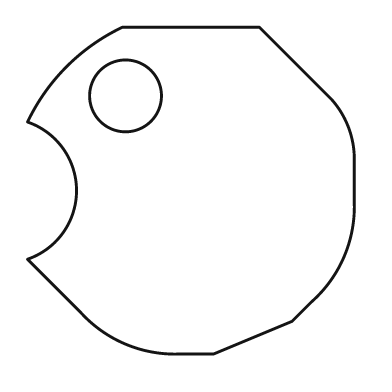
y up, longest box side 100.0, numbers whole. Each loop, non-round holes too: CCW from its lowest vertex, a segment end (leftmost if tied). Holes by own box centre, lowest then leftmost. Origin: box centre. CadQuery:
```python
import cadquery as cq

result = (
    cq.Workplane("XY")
    .moveTo(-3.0, -50.0)
    .lineTo(7.0, -50.0)
    .lineTo(31.0, -40.0)
    .lineTo(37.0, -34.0)
    .threePointArc((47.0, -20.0), (50.0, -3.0))
    .lineTo(50.0, 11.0)
    .threePointArc((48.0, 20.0), (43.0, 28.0))
    .lineTo(21.0, 50.0)
    .lineTo(-21.0, 50.0)
    .threePointArc((-38.0, 38.0), (-50.0, 21.0))
    .threePointArc((-35.0, 0.0), (-50.0, -21.0))
    .lineTo(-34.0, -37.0)
    .threePointArc((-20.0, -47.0), (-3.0, -50.0))
    .close()
    .moveTo(-20.0, 29.0)
    .circle(11.0)
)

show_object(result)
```